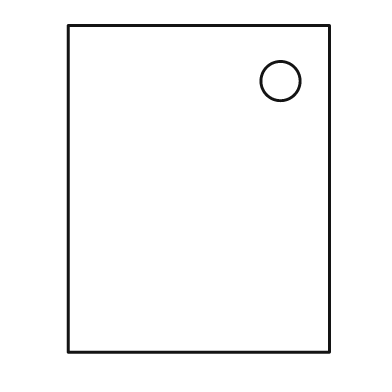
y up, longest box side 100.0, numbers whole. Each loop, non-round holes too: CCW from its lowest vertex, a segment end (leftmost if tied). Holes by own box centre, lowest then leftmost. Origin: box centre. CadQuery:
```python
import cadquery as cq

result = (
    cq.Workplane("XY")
    .moveTo(-40.0, -50.0)
    .lineTo(40.0, -50.0)
    .lineTo(40.0, 50.0)
    .lineTo(-40.0, 50.0)
    .close()
    .moveTo(25.0, 33.0)
    .circle(6.0)
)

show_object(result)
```